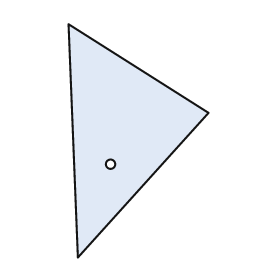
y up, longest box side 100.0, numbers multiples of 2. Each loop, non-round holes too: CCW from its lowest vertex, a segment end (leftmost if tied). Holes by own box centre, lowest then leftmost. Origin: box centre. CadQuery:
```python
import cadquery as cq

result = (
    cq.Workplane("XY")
    .moveTo(-26.0, -50.0)
    .lineTo(30.0, 12.0)
    .lineTo(-30.0, 50.0)
    .close()
    .moveTo(-12.0, -10.0)
    .circle(2.0)
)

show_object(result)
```